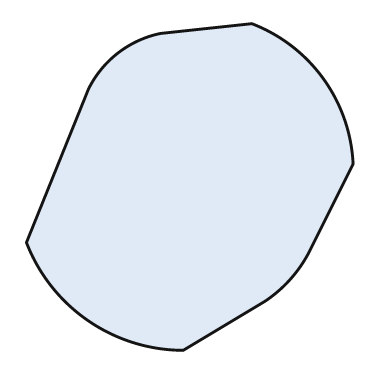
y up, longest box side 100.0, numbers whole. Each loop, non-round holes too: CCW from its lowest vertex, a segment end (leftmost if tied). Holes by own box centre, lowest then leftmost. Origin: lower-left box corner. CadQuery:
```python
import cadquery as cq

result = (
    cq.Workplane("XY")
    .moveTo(48.0, 0.0)
    .lineTo(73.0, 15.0)
    .threePointArc((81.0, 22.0), (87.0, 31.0))
    .lineTo(100.0, 57.0)
    .threePointArc((91.0, 83.0), (69.0, 100.0))
    .lineTo(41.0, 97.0)
    .threePointArc((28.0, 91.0), (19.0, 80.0))
    .lineTo(0.0, 33.0)
    .threePointArc((19.0, 9.0), (48.0, 0.0))
    .close()
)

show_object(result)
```